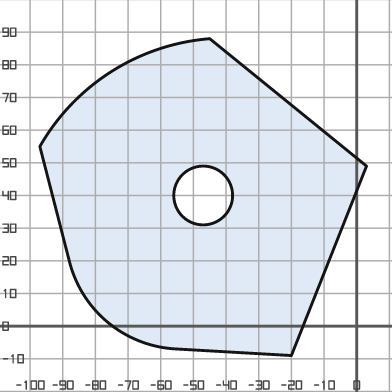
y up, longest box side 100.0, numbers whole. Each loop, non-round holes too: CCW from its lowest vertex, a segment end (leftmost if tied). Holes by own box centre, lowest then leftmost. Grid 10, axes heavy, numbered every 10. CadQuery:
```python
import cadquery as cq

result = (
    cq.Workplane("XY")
    .moveTo(-20.0, -9.0)
    .lineTo(3.0, 49.0)
    .lineTo(-45.0, 88.0)
    .threePointArc((-75.0, 78.0), (-97.0, 55.0))
    .lineTo(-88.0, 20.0)
    .threePointArc((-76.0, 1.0), (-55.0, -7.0))
    .close()
    .moveTo(-47.0, 40.0)
    .circle(9.0)
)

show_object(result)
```